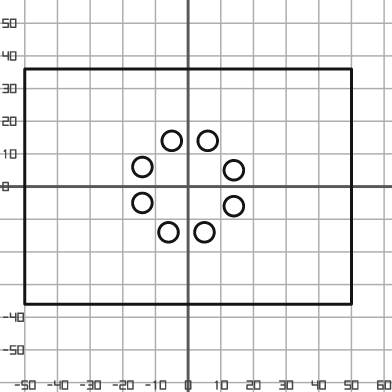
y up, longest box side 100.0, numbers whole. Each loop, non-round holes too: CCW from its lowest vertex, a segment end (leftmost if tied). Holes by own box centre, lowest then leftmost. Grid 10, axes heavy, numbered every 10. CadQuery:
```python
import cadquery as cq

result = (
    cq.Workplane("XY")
    .moveTo(-50.0, -36.0)
    .lineTo(50.0, -36.0)
    .lineTo(50.0, 36.0)
    .lineTo(-50.0, 36.0)
    .close()
    .moveTo(-6.0, -14.0)
    .circle(3.0)
    .moveTo(5.0, -14.0)
    .circle(3.0)
    .moveTo(14.0, -6.0)
    .circle(3.0)
    .moveTo(-14.0, -5.0)
    .circle(3.0)
    .moveTo(14.0, 5.0)
    .circle(3.0)
    .moveTo(-14.0, 6.0)
    .circle(3.0)
    .moveTo(-5.0, 14.0)
    .circle(3.0)
    .moveTo(6.0, 14.0)
    .circle(3.0)
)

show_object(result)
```